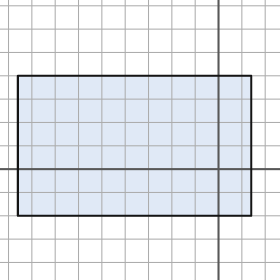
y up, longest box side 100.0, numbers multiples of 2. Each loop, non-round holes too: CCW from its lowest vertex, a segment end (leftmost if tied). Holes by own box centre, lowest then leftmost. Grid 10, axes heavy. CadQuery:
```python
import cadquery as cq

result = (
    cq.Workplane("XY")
    .moveTo(-86.0, -20.0)
    .lineTo(14.0, -20.0)
    .lineTo(14.0, 40.0)
    .lineTo(-86.0, 40.0)
    .close()
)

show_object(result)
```